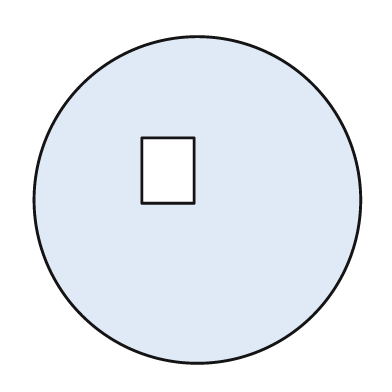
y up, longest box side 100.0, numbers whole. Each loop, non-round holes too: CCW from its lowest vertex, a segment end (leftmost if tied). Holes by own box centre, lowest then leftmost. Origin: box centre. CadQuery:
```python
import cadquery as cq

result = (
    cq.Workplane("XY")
    .moveTo(0.0, 0.0)
    .circle(50.0)
    .moveTo(-17.0, -1.0)
    .lineTo(-1.0, -1.0)
    .lineTo(-1.0, 19.0)
    .lineTo(-17.0, 19.0)
    .close()
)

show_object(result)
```